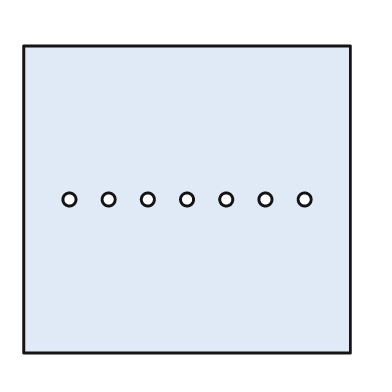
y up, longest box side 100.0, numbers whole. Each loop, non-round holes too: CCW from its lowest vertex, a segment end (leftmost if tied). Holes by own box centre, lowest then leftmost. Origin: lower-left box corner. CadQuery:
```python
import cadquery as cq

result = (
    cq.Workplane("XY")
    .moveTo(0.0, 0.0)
    .lineTo(100.0, 0.0)
    .lineTo(100.0, 94.0)
    .lineTo(0.0, 94.0)
    .close()
    .moveTo(14.0, 47.0)
    .circle(2.0)
    .moveTo(26.0, 47.0)
    .circle(2.0)
    .moveTo(38.0, 47.0)
    .circle(2.0)
    .moveTo(50.0, 47.0)
    .circle(2.0)
    .moveTo(62.0, 47.0)
    .circle(2.0)
    .moveTo(74.0, 47.0)
    .circle(2.0)
    .moveTo(86.0, 47.0)
    .circle(2.0)
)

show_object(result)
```